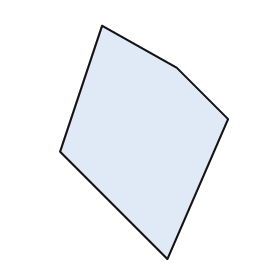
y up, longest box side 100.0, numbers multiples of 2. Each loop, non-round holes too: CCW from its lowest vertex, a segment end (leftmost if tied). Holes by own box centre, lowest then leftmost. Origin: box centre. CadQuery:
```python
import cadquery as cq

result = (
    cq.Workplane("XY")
    .moveTo(10.0, -50.0)
    .lineTo(36.0, 10.0)
    .lineTo(14.0, 32.0)
    .lineTo(-18.0, 50.0)
    .lineTo(-36.0, -4.0)
    .close()
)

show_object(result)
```